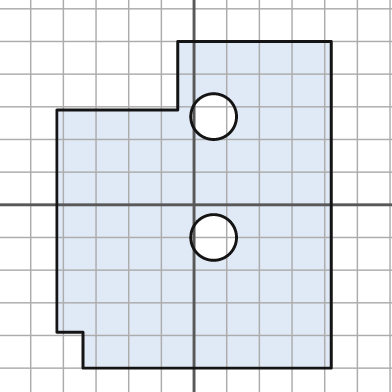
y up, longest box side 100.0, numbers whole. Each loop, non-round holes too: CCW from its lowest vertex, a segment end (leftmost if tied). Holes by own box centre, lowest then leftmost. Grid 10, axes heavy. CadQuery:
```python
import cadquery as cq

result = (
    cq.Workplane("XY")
    .moveTo(-34.0, -50.0)
    .lineTo(42.0, -50.0)
    .lineTo(42.0, 50.0)
    .lineTo(-5.0, 50.0)
    .lineTo(-5.0, 29.0)
    .lineTo(-42.0, 29.0)
    .lineTo(-42.0, -39.0)
    .lineTo(-34.0, -39.0)
    .close()
    .moveTo(6.0, -10.0)
    .circle(7.0)
    .moveTo(6.0, 27.0)
    .circle(7.0)
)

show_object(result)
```